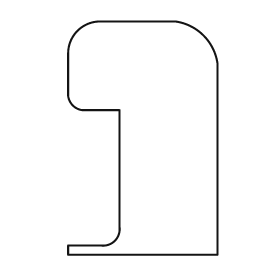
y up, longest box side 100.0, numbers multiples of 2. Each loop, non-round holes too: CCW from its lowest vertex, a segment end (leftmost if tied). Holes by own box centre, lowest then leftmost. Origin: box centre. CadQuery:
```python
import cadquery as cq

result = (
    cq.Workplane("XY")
    .moveTo(-32.0, -50.0)
    .lineTo(32.0, -50.0)
    .lineTo(32.0, 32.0)
    .threePointArc((26.0, 44.0), (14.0, 50.0))
    .lineTo(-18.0, 50.0)
    .threePointArc((-28.0, 46.0), (-32.0, 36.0))
    .lineTo(-32.0, 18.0)
    .threePointArc((-30.0, 14.0), (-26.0, 12.0))
    .lineTo(-10.0, 12.0)
    .lineTo(-10.0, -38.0)
    .threePointArc((-12.0, -44.0), (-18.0, -46.0))
    .lineTo(-32.0, -46.0)
    .close()
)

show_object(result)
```